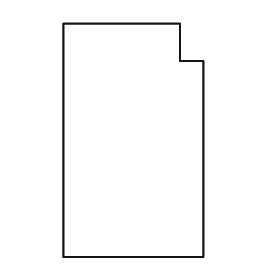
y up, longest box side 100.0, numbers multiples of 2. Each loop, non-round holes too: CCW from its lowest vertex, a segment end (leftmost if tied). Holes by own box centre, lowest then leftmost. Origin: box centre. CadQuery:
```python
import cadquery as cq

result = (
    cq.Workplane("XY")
    .moveTo(-30.0, -50.0)
    .lineTo(30.0, -50.0)
    .lineTo(30.0, 34.0)
    .lineTo(20.0, 34.0)
    .lineTo(20.0, 50.0)
    .lineTo(-30.0, 50.0)
    .close()
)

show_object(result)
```